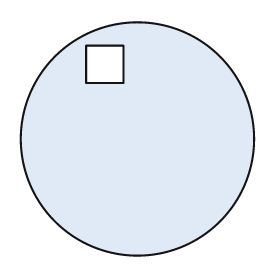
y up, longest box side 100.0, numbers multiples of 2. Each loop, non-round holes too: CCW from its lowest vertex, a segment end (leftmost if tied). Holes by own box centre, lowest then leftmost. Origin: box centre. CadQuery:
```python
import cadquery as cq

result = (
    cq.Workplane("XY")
    .moveTo(0.0, 0.0)
    .circle(50.0)
    .moveTo(-22.0, 24.0)
    .lineTo(-6.0, 24.0)
    .lineTo(-6.0, 40.0)
    .lineTo(-22.0, 40.0)
    .close()
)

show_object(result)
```